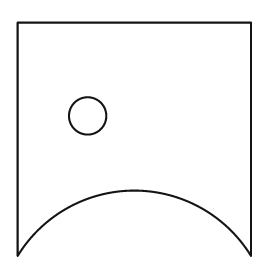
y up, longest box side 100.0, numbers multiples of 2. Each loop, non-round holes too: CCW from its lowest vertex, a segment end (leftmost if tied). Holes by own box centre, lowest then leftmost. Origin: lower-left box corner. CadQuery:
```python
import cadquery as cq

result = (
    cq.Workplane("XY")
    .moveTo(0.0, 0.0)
    .threePointArc((50.0, 28.0), (100.0, 0.0))
    .lineTo(100.0, 100.0)
    .lineTo(0.0, 100.0)
    .close()
    .moveTo(30.0, 60.0)
    .circle(8.0)
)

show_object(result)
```